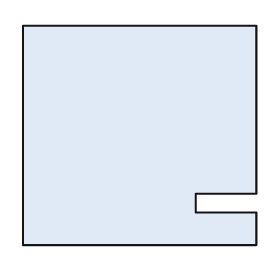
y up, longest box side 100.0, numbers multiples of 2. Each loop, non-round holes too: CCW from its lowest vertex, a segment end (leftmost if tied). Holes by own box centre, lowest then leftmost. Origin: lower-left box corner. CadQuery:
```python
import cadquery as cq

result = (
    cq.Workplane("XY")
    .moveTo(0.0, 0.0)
    .lineTo(100.0, 0.0)
    .lineTo(100.0, 14.0)
    .lineTo(74.0, 14.0)
    .lineTo(74.0, 22.0)
    .lineTo(100.0, 22.0)
    .lineTo(100.0, 94.0)
    .lineTo(0.0, 94.0)
    .close()
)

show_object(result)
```